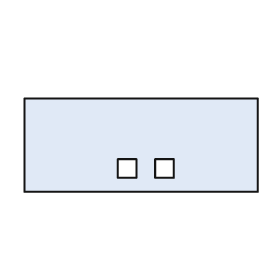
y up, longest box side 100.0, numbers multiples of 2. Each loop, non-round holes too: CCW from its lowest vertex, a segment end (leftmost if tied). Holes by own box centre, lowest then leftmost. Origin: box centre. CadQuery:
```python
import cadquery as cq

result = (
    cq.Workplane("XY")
    .moveTo(-50.0, -20.0)
    .lineTo(50.0, -20.0)
    .lineTo(50.0, 20.0)
    .lineTo(-50.0, 20.0)
    .close()
    .moveTo(-10.0, -14.0)
    .lineTo(-2.0, -14.0)
    .lineTo(-2.0, -6.0)
    .lineTo(-10.0, -6.0)
    .close()
    .moveTo(6.0, -14.0)
    .lineTo(14.0, -14.0)
    .lineTo(14.0, -6.0)
    .lineTo(6.0, -6.0)
    .close()
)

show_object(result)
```